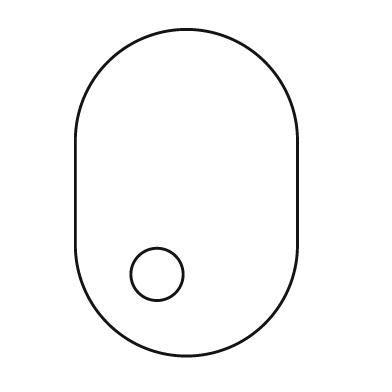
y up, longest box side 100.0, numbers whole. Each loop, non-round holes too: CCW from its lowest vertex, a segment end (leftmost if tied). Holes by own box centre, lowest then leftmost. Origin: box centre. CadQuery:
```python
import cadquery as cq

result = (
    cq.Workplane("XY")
    .moveTo(-34.0, -16.0)
    .threePointArc((0.0, -50.0), (34.0, -16.0))
    .lineTo(34.0, 16.0)
    .threePointArc((0.0, 50.0), (-34.0, 16.0))
    .close()
    .moveTo(-9.0, -25.0)
    .circle(8.0)
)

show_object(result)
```